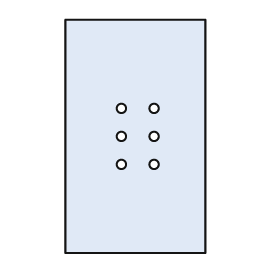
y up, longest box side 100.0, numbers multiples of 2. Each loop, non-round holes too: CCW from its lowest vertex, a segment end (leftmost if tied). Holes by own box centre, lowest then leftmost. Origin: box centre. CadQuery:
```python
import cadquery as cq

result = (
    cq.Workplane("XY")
    .moveTo(-30.0, -50.0)
    .lineTo(30.0, -50.0)
    .lineTo(30.0, 50.0)
    .lineTo(-30.0, 50.0)
    .close()
    .moveTo(-6.0, -12.0)
    .circle(2.0)
    .moveTo(8.0, -12.0)
    .circle(2.0)
    .moveTo(-6.0, 0.0)
    .circle(2.0)
    .moveTo(8.0, 0.0)
    .circle(2.0)
    .moveTo(-6.0, 12.0)
    .circle(2.0)
    .moveTo(8.0, 12.0)
    .circle(2.0)
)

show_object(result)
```